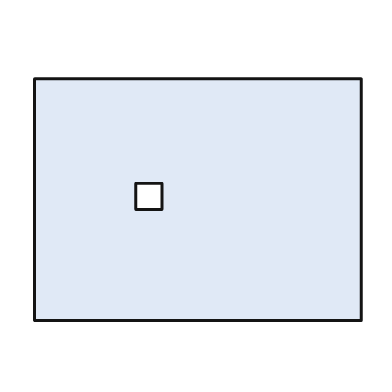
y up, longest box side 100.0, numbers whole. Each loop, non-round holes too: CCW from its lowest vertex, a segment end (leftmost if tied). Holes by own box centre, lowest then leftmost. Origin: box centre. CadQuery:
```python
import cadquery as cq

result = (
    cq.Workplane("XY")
    .moveTo(-50.0, -37.0)
    .lineTo(50.0, -37.0)
    .lineTo(50.0, 37.0)
    .lineTo(-50.0, 37.0)
    .close()
    .moveTo(-19.0, -3.0)
    .lineTo(-11.0, -3.0)
    .lineTo(-11.0, 5.0)
    .lineTo(-19.0, 5.0)
    .close()
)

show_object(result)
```